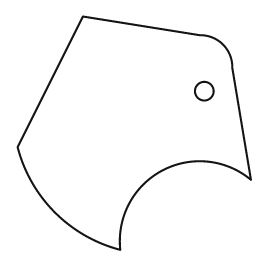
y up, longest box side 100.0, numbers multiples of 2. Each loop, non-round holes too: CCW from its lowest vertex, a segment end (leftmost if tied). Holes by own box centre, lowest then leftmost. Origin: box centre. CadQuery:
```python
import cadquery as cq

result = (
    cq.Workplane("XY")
    .moveTo(-6.0, -50.0)
    .threePointArc((12.0, -16.0), (50.0, -20.0))
    .lineTo(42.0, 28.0)
    .threePointArc((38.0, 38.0), (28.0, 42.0))
    .lineTo(-22.0, 50.0)
    .lineTo(-50.0, -6.0)
    .threePointArc((-34.0, -34.0), (-6.0, -50.0))
    .close()
    .moveTo(30.0, 18.0)
    .circle(4.0)
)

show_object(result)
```